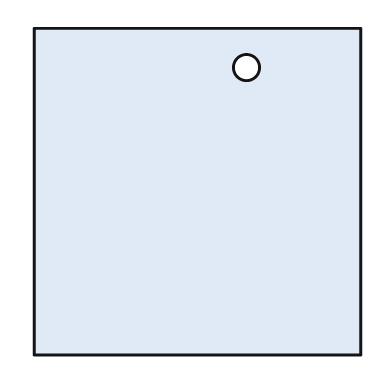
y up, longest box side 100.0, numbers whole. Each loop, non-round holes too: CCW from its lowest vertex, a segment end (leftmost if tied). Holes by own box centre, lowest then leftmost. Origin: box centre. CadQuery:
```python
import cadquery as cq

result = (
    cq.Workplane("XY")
    .moveTo(-50.0, -50.0)
    .lineTo(50.0, -50.0)
    .lineTo(50.0, 50.0)
    .lineTo(-50.0, 50.0)
    .close()
    .moveTo(15.0, 38.0)
    .circle(4.0)
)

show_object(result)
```